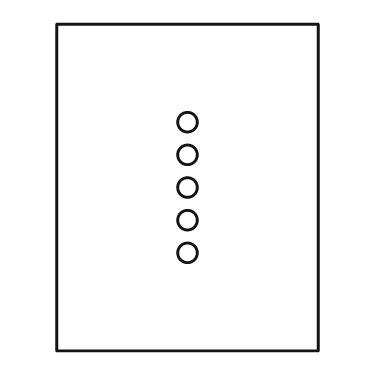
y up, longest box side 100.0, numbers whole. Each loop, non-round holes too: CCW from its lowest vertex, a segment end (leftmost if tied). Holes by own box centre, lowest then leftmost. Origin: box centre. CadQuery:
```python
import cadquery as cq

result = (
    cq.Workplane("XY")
    .moveTo(-40.0, -50.0)
    .lineTo(40.0, -50.0)
    .lineTo(40.0, 50.0)
    .lineTo(-40.0, 50.0)
    .close()
    .moveTo(0.0, -20.0)
    .circle(3.0)
    .moveTo(0.0, -10.0)
    .circle(3.0)
    .moveTo(0.0, 0.0)
    .circle(3.0)
    .moveTo(0.0, 10.0)
    .circle(3.0)
    .moveTo(0.0, 20.0)
    .circle(3.0)
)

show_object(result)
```